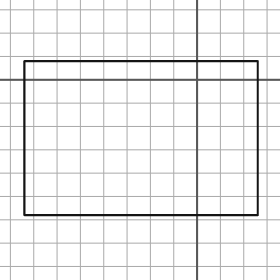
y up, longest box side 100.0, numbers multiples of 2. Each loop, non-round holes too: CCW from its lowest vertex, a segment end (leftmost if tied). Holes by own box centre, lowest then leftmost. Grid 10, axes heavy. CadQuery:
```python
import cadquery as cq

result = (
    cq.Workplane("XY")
    .moveTo(-74.0, -58.0)
    .lineTo(26.0, -58.0)
    .lineTo(26.0, 8.0)
    .lineTo(-74.0, 8.0)
    .close()
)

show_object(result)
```